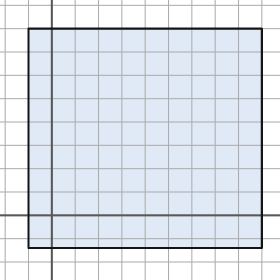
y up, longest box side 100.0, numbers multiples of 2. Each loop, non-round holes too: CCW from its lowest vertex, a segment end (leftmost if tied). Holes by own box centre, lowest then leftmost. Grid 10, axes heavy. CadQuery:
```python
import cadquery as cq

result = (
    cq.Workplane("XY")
    .moveTo(-10.0, -14.0)
    .lineTo(90.0, -14.0)
    .lineTo(90.0, 80.0)
    .lineTo(-10.0, 80.0)
    .close()
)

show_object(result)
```